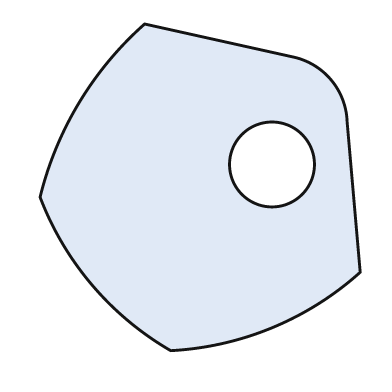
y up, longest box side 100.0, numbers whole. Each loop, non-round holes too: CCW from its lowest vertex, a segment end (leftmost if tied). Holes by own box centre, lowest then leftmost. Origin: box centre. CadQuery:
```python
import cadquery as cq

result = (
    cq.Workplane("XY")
    .moveTo(-9.0, -50.0)
    .threePointArc((22.0, -43.0), (49.0, -26.0))
    .lineTo(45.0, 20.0)
    .threePointArc((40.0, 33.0), (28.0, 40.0))
    .lineTo(-17.0, 50.0)
    .threePointArc((-37.0, 26.0), (-49.0, -3.0))
    .threePointArc((-33.0, -30.0), (-9.0, -50.0))
    .close()
    .moveTo(22.0, 7.0)
    .circle(13.0)
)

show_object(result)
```